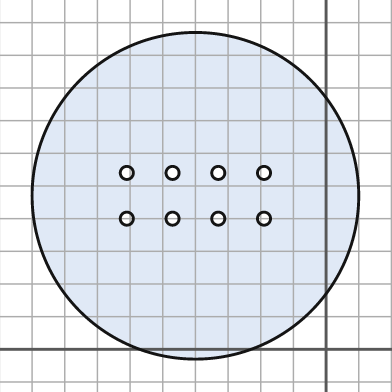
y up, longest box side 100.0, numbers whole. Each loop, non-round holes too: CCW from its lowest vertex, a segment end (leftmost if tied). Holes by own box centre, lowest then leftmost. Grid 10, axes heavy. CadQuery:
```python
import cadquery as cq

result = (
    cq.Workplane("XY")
    .moveTo(-40.0, 47.0)
    .circle(50.0)
    .moveTo(-61.0, 40.0)
    .circle(2.0)
    .moveTo(-47.0, 40.0)
    .circle(2.0)
    .moveTo(-33.0, 40.0)
    .circle(2.0)
    .moveTo(-19.0, 40.0)
    .circle(2.0)
    .moveTo(-61.0, 54.0)
    .circle(2.0)
    .moveTo(-47.0, 54.0)
    .circle(2.0)
    .moveTo(-33.0, 54.0)
    .circle(2.0)
    .moveTo(-19.0, 54.0)
    .circle(2.0)
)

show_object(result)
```